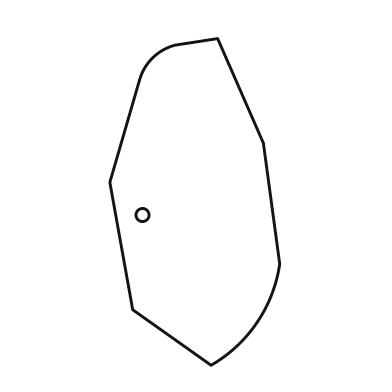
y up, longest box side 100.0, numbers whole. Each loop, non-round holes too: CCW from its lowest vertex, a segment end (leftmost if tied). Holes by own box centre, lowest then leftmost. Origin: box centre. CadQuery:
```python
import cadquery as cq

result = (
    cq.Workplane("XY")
    .moveTo(5.0, -50.0)
    .threePointArc((19.0, -37.0), (26.0, -19.0))
    .lineTo(21.0, 18.0)
    .lineTo(7.0, 50.0)
    .lineTo(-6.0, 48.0)
    .threePointArc((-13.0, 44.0), (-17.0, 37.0))
    .lineTo(-26.0, 6.0)
    .lineTo(-19.0, -33.0)
    .close()
    .moveTo(-16.0, -4.0)
    .circle(2.0)
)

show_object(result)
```